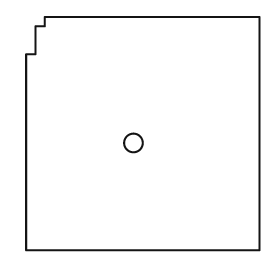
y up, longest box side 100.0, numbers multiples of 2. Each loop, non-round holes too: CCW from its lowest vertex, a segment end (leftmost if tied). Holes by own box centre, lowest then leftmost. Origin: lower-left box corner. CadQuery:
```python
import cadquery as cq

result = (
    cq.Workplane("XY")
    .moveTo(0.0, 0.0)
    .lineTo(100.0, 0.0)
    .lineTo(100.0, 100.0)
    .lineTo(8.0, 100.0)
    .lineTo(8.0, 96.0)
    .lineTo(4.0, 96.0)
    .lineTo(4.0, 84.0)
    .lineTo(0.0, 84.0)
    .close()
    .moveTo(46.0, 46.0)
    .circle(4.0)
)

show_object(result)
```